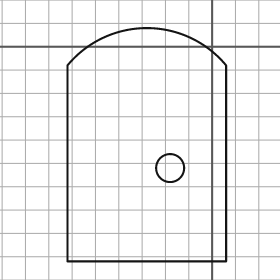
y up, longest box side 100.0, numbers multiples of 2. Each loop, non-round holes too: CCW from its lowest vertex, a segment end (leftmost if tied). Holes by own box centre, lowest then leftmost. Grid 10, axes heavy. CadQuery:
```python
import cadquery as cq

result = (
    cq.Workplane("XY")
    .moveTo(-62.0, -92.0)
    .lineTo(6.0, -92.0)
    .lineTo(6.0, -8.0)
    .threePointArc((-28.0, 8.0), (-62.0, -8.0))
    .close()
    .moveTo(-18.0, -52.0)
    .circle(6.0)
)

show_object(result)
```